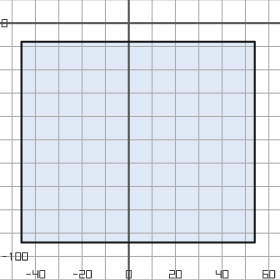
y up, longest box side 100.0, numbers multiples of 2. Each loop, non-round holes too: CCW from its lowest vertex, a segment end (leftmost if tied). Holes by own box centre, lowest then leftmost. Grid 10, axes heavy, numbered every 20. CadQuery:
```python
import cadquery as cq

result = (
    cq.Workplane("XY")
    .moveTo(-46.0, -94.0)
    .lineTo(54.0, -94.0)
    .lineTo(54.0, -8.0)
    .lineTo(-46.0, -8.0)
    .close()
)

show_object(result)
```